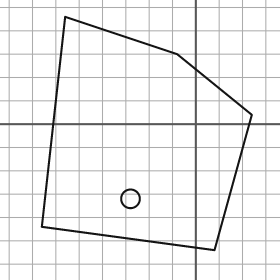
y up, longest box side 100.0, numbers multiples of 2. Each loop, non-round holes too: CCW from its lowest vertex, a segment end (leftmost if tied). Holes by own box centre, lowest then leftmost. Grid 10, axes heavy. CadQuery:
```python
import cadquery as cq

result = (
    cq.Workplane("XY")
    .moveTo(8.0, -54.0)
    .lineTo(24.0, 4.0)
    .lineTo(-8.0, 30.0)
    .lineTo(-56.0, 46.0)
    .lineTo(-66.0, -44.0)
    .close()
    .moveTo(-28.0, -32.0)
    .circle(4.0)
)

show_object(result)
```